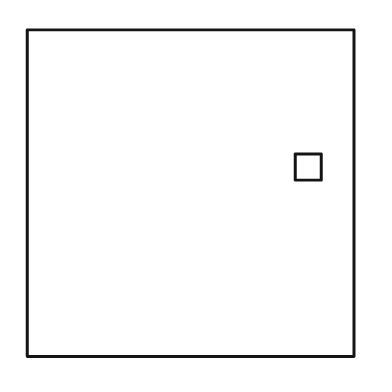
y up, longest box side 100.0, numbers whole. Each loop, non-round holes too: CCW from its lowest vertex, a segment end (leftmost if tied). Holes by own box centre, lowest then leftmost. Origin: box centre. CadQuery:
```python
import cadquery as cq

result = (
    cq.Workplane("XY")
    .moveTo(-50.0, -50.0)
    .lineTo(50.0, -50.0)
    .lineTo(50.0, 50.0)
    .lineTo(-50.0, 50.0)
    .close()
    .moveTo(32.0, 4.0)
    .lineTo(40.0, 4.0)
    .lineTo(40.0, 12.0)
    .lineTo(32.0, 12.0)
    .close()
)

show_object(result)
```